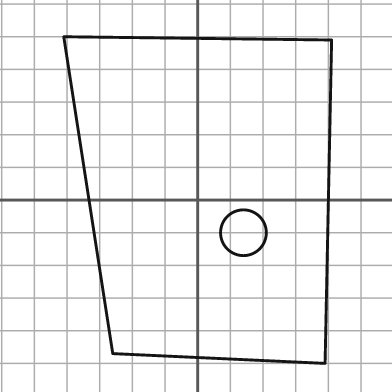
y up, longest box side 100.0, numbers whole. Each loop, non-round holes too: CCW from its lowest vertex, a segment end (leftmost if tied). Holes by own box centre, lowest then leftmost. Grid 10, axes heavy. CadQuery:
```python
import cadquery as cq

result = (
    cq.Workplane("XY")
    .moveTo(39.0, -50.0)
    .lineTo(41.0, 49.0)
    .lineTo(-41.0, 50.0)
    .lineTo(-26.0, -47.0)
    .close()
    .moveTo(14.0, -10.0)
    .circle(7.0)
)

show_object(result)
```